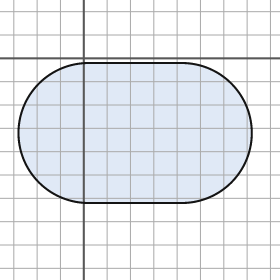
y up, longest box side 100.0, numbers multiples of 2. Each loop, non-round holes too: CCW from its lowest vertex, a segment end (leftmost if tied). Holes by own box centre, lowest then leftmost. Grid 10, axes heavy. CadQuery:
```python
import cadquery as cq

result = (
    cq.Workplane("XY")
    .moveTo(2.0, -62.0)
    .lineTo(42.0, -62.0)
    .threePointArc((72.0, -32.0), (42.0, -2.0))
    .lineTo(2.0, -2.0)
    .threePointArc((-28.0, -32.0), (2.0, -62.0))
    .close()
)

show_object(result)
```